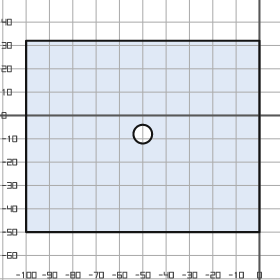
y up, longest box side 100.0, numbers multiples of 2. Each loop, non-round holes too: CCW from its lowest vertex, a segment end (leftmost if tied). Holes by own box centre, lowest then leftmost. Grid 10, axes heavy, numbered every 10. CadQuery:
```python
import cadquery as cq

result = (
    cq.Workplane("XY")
    .moveTo(-100.0, -50.0)
    .lineTo(0.0, -50.0)
    .lineTo(0.0, 32.0)
    .lineTo(-100.0, 32.0)
    .close()
    .moveTo(-50.0, -8.0)
    .circle(4.0)
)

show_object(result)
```